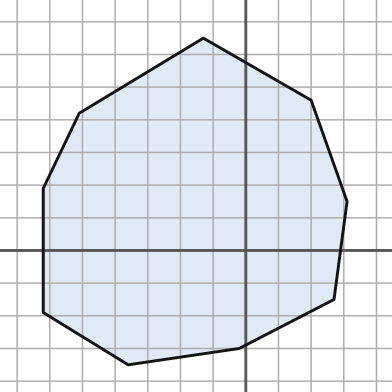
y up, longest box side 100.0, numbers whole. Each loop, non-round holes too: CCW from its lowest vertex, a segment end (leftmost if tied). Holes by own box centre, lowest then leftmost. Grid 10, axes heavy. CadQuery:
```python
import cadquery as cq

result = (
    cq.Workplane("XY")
    .moveTo(-36.0, -35.0)
    .lineTo(-2.0, -30.0)
    .lineTo(27.0, -15.0)
    .lineTo(31.0, 15.0)
    .lineTo(20.0, 46.0)
    .lineTo(-13.0, 65.0)
    .lineTo(-51.0, 42.0)
    .lineTo(-62.0, 19.0)
    .lineTo(-62.0, -19.0)
    .close()
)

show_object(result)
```